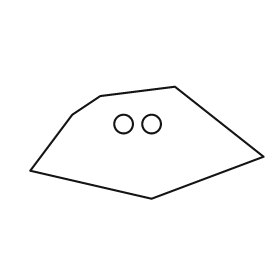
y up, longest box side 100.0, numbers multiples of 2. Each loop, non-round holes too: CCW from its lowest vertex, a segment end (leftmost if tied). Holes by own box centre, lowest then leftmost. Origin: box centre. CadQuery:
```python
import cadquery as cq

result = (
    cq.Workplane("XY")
    .moveTo(2.0, -24.0)
    .lineTo(50.0, -6.0)
    .lineTo(12.0, 24.0)
    .lineTo(-20.0, 20.0)
    .lineTo(-32.0, 12.0)
    .lineTo(-50.0, -12.0)
    .close()
    .moveTo(-10.0, 8.0)
    .circle(4.0)
    .moveTo(2.0, 8.0)
    .circle(4.0)
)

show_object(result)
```